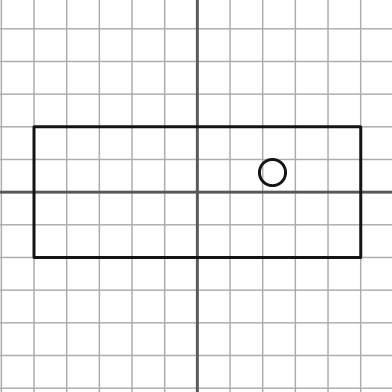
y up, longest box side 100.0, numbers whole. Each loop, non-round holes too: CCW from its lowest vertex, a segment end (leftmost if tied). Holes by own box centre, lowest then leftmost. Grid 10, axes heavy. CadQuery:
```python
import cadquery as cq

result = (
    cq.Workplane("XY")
    .moveTo(-50.0, -20.0)
    .lineTo(50.0, -20.0)
    .lineTo(50.0, 20.0)
    .lineTo(-50.0, 20.0)
    .close()
    .moveTo(23.0, 6.0)
    .circle(4.0)
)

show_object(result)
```